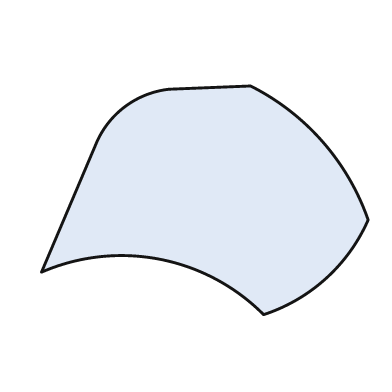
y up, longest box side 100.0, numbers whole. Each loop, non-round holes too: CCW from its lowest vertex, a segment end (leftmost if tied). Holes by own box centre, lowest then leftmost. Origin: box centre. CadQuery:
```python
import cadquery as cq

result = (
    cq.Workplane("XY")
    .moveTo(18.0, -35.0)
    .threePointArc((37.0, -24.0), (50.0, -6.0))
    .threePointArc((36.0, 18.0), (14.0, 35.0))
    .lineTo(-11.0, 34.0)
    .threePointArc((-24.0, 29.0), (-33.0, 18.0))
    .lineTo(-50.0, -22.0)
    .threePointArc((-14.0, -18.0), (18.0, -35.0))
    .close()
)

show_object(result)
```